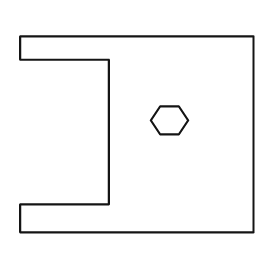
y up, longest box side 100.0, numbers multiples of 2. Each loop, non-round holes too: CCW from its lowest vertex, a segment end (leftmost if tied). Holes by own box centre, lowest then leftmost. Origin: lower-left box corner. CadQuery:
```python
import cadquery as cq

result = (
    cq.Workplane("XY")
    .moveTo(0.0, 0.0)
    .lineTo(100.0, 0.0)
    .lineTo(100.0, 84.0)
    .lineTo(0.0, 84.0)
    .lineTo(0.0, 74.0)
    .lineTo(38.0, 74.0)
    .lineTo(38.0, 12.0)
    .lineTo(0.0, 12.0)
    .close()
    .moveTo(60.0, 42.0)
    .lineTo(68.0, 42.0)
    .lineTo(72.0, 48.0)
    .lineTo(68.0, 54.0)
    .lineTo(60.0, 54.0)
    .lineTo(56.0, 48.0)
    .close()
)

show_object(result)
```